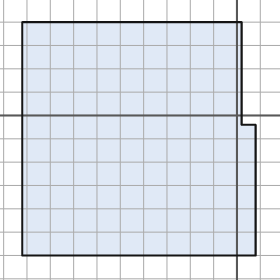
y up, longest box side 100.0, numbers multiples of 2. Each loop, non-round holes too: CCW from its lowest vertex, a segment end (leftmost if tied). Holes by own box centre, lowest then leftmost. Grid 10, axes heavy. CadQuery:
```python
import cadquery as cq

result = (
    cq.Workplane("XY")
    .moveTo(-92.0, -60.0)
    .lineTo(8.0, -60.0)
    .lineTo(8.0, -4.0)
    .lineTo(2.0, -4.0)
    .lineTo(2.0, 40.0)
    .lineTo(-92.0, 40.0)
    .close()
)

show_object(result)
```